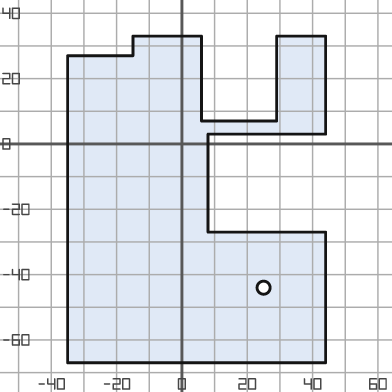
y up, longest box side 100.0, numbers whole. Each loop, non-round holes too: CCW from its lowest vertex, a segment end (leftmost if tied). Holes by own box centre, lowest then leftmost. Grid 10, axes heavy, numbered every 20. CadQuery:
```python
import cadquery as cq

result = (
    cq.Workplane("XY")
    .moveTo(-35.0, -67.0)
    .lineTo(44.0, -67.0)
    .lineTo(44.0, -27.0)
    .lineTo(8.0, -27.0)
    .lineTo(8.0, 3.0)
    .lineTo(44.0, 3.0)
    .lineTo(44.0, 33.0)
    .lineTo(29.0, 33.0)
    .lineTo(29.0, 7.0)
    .lineTo(6.0, 7.0)
    .lineTo(6.0, 33.0)
    .lineTo(-15.0, 33.0)
    .lineTo(-15.0, 27.0)
    .lineTo(-35.0, 27.0)
    .close()
    .moveTo(25.0, -44.0)
    .circle(2.0)
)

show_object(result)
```